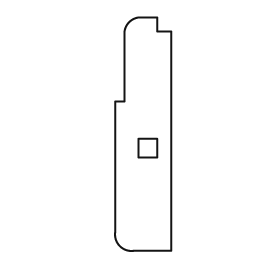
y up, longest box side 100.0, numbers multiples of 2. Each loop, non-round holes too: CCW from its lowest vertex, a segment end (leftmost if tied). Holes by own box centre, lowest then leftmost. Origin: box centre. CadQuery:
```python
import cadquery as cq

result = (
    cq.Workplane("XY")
    .moveTo(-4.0, -50.0)
    .lineTo(12.0, -50.0)
    .lineTo(12.0, 44.0)
    .lineTo(6.0, 44.0)
    .lineTo(6.0, 50.0)
    .lineTo(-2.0, 50.0)
    .threePointArc((-6.0, 48.0), (-8.0, 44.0))
    .lineTo(-8.0, 14.0)
    .lineTo(-12.0, 14.0)
    .lineTo(-12.0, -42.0)
    .threePointArc((-10.0, -48.0), (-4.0, -50.0))
    .close()
    .moveTo(-2.0, -10.0)
    .lineTo(6.0, -10.0)
    .lineTo(6.0, -2.0)
    .lineTo(-2.0, -2.0)
    .close()
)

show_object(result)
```